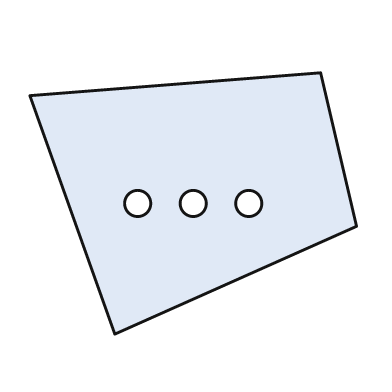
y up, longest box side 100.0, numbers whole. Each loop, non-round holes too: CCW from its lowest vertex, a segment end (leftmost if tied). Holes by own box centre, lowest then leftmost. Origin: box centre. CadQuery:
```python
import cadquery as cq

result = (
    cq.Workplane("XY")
    .moveTo(-24.0, -40.0)
    .lineTo(50.0, -7.0)
    .lineTo(39.0, 40.0)
    .lineTo(-50.0, 33.0)
    .close()
    .moveTo(-17.0, 0.0)
    .circle(4.0)
    .moveTo(0.0, 0.0)
    .circle(4.0)
    .moveTo(17.0, 0.0)
    .circle(4.0)
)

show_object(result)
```